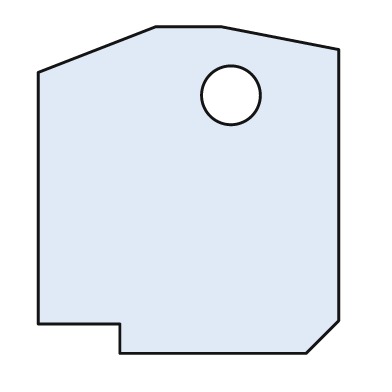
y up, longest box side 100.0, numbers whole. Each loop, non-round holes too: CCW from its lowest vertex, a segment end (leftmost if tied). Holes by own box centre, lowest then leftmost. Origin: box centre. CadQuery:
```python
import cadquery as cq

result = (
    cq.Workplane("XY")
    .moveTo(-21.0, -50.0)
    .lineTo(36.0, -50.0)
    .lineTo(46.0, -40.0)
    .lineTo(46.0, 43.0)
    .lineTo(10.0, 50.0)
    .lineTo(-10.0, 50.0)
    .lineTo(-46.0, 36.0)
    .lineTo(-46.0, -41.0)
    .lineTo(-21.0, -41.0)
    .close()
    .moveTo(13.0, 29.0)
    .circle(9.0)
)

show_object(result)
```